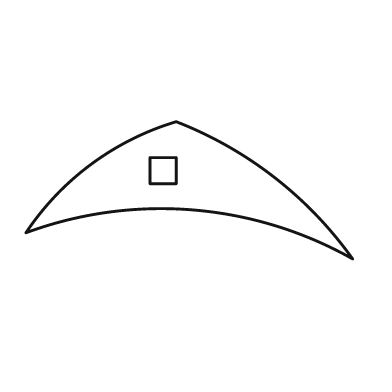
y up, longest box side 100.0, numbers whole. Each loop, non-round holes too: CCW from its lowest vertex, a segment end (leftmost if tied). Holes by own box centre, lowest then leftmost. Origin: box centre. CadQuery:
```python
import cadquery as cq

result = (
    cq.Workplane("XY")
    .moveTo(50.0, -21.0)
    .threePointArc((26.0, 4.0), (-4.0, 21.0))
    .threePointArc((-30.0, 8.0), (-50.0, -13.0))
    .threePointArc((1.0, -6.0), (50.0, -21.0))
    .close()
    .moveTo(-12.0, 2.0)
    .lineTo(-4.0, 2.0)
    .lineTo(-4.0, 10.0)
    .lineTo(-12.0, 10.0)
    .close()
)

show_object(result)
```